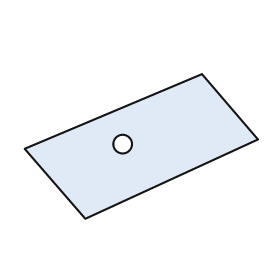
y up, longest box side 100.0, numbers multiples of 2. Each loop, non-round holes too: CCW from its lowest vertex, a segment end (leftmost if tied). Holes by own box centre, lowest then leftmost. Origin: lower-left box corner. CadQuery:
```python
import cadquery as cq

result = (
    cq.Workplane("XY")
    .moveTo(26.0, 0.0)
    .lineTo(100.0, 34.0)
    .lineTo(76.0, 62.0)
    .lineTo(0.0, 30.0)
    .close()
    .moveTo(42.0, 32.0)
    .circle(4.0)
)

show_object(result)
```